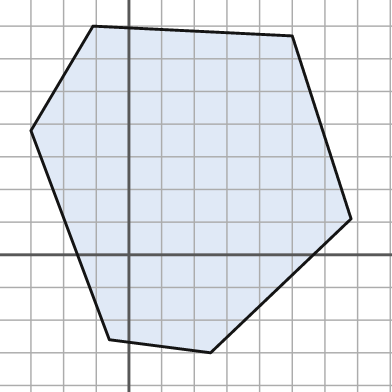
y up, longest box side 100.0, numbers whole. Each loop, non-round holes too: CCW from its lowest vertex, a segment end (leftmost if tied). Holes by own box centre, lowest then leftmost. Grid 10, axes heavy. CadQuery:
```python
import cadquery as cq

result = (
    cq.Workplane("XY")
    .moveTo(25.0, -30.0)
    .lineTo(68.0, 11.0)
    .lineTo(50.0, 67.0)
    .lineTo(-11.0, 70.0)
    .lineTo(-30.0, 38.0)
    .lineTo(-6.0, -26.0)
    .close()
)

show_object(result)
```